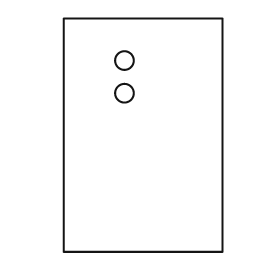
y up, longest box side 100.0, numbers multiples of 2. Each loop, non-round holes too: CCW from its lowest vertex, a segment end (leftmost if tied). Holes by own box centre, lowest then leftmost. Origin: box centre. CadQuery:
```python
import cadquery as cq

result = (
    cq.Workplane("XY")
    .moveTo(-34.0, -50.0)
    .lineTo(34.0, -50.0)
    .lineTo(34.0, 50.0)
    .lineTo(-34.0, 50.0)
    .close()
    .moveTo(-8.0, 18.0)
    .circle(4.0)
    .moveTo(-8.0, 32.0)
    .circle(4.0)
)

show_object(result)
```